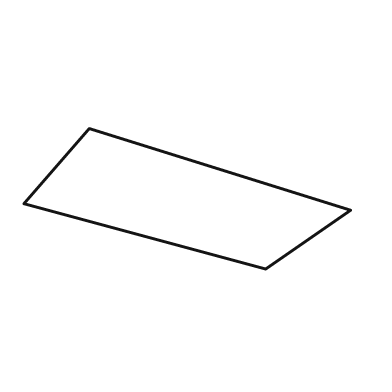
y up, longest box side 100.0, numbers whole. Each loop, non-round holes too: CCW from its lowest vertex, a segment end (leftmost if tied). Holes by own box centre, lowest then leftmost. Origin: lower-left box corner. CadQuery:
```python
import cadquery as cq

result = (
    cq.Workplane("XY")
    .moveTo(74.0, 0.0)
    .lineTo(100.0, 18.0)
    .lineTo(20.0, 43.0)
    .lineTo(0.0, 20.0)
    .close()
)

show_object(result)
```